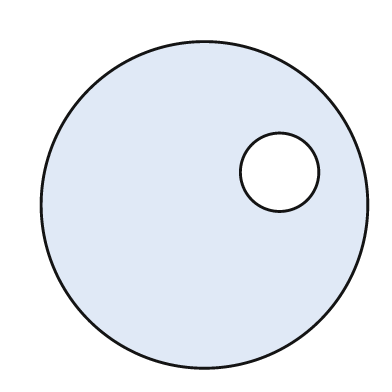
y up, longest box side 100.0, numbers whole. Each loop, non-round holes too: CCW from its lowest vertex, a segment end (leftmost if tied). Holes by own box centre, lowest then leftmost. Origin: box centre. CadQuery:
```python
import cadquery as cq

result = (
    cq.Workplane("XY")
    .moveTo(0.0, 0.0)
    .circle(50.0)
    .moveTo(23.0, 10.0)
    .circle(12.0)
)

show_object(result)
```